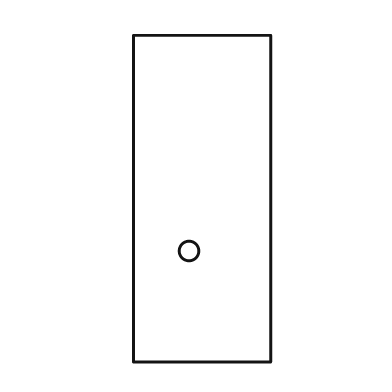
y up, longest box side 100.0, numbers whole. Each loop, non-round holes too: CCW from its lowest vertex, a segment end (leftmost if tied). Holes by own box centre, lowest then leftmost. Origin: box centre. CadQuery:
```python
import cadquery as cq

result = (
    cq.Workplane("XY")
    .moveTo(-21.0, -50.0)
    .lineTo(21.0, -50.0)
    .lineTo(21.0, 50.0)
    .lineTo(-21.0, 50.0)
    .close()
    .moveTo(-4.0, -16.0)
    .circle(3.0)
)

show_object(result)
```